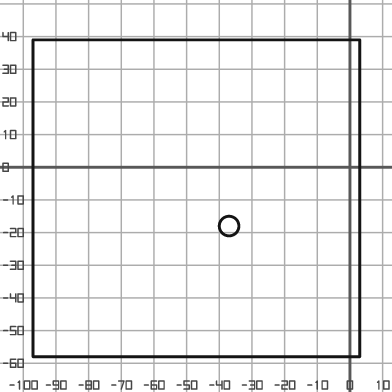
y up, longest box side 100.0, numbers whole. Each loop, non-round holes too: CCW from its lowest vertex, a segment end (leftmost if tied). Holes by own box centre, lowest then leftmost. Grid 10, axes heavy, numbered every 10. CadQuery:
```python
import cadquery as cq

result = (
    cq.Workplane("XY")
    .moveTo(-97.0, -58.0)
    .lineTo(3.0, -58.0)
    .lineTo(3.0, 39.0)
    .lineTo(-97.0, 39.0)
    .close()
    .moveTo(-37.0, -18.0)
    .circle(3.0)
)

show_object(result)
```